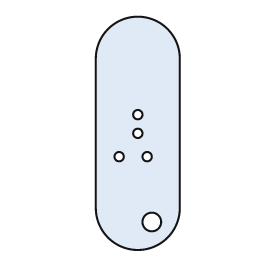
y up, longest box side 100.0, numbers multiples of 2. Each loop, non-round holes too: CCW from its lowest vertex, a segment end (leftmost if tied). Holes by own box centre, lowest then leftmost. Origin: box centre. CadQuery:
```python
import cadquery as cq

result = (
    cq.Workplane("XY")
    .moveTo(-18.0, -32.0)
    .threePointArc((0.0, -50.0), (18.0, -32.0))
    .lineTo(18.0, 32.0)
    .threePointArc((0.0, 50.0), (-18.0, 32.0))
    .close()
    .moveTo(6.0, -38.0)
    .circle(4.0)
    .moveTo(-8.0, -10.0)
    .circle(2.0)
    .moveTo(4.0, -10.0)
    .circle(2.0)
    .moveTo(0.0, 0.0)
    .circle(2.0)
    .moveTo(0.0, 8.0)
    .circle(2.0)
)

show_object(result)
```